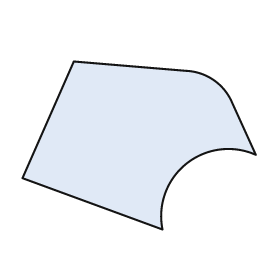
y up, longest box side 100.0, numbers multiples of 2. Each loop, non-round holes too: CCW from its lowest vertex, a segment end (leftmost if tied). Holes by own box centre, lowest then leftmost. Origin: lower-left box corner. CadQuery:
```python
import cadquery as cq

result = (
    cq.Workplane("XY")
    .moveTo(60.0, 0.0)
    .threePointArc((70.0, 28.0), (100.0, 32.0))
    .lineTo(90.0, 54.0)
    .threePointArc((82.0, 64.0), (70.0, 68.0))
    .lineTo(22.0, 72.0)
    .lineTo(0.0, 22.0)
    .close()
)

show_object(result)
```